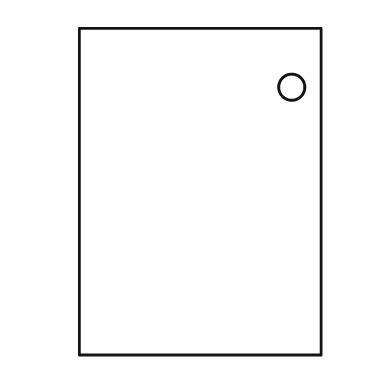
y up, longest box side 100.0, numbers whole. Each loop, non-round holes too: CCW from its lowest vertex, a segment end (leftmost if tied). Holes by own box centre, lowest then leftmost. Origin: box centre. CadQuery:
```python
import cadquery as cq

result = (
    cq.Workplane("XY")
    .moveTo(-37.0, -50.0)
    .lineTo(37.0, -50.0)
    .lineTo(37.0, 50.0)
    .lineTo(-37.0, 50.0)
    .close()
    .moveTo(28.0, 32.0)
    .circle(4.0)
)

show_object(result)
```